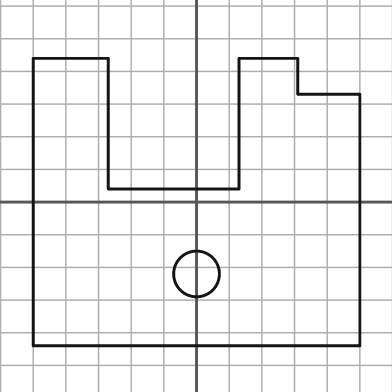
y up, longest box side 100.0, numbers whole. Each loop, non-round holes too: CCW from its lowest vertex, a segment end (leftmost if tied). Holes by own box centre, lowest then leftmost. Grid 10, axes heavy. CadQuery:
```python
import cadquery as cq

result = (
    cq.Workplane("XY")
    .moveTo(-50.0, -44.0)
    .lineTo(50.0, -44.0)
    .lineTo(50.0, 33.0)
    .lineTo(31.0, 33.0)
    .lineTo(31.0, 44.0)
    .lineTo(13.0, 44.0)
    .lineTo(13.0, 4.0)
    .lineTo(-27.0, 4.0)
    .lineTo(-27.0, 44.0)
    .lineTo(-50.0, 44.0)
    .close()
    .moveTo(0.0, -22.0)
    .circle(7.0)
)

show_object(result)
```